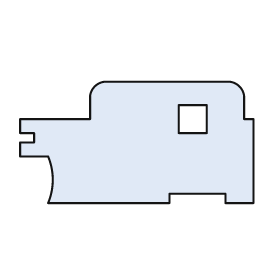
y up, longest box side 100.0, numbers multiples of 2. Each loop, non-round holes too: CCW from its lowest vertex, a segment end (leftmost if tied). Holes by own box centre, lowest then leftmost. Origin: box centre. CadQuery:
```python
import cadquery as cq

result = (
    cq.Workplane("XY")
    .moveTo(-38.0, -26.0)
    .lineTo(14.0, -26.0)
    .lineTo(14.0, -22.0)
    .lineTo(38.0, -22.0)
    .lineTo(38.0, -26.0)
    .lineTo(50.0, -26.0)
    .lineTo(50.0, 10.0)
    .lineTo(46.0, 10.0)
    .lineTo(46.0, 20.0)
    .threePointArc((44.0, 24.0), (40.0, 26.0))
    .lineTo(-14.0, 26.0)
    .threePointArc((-18.0, 24.0), (-20.0, 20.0))
    .lineTo(-20.0, 10.0)
    .lineTo(-50.0, 10.0)
    .lineTo(-50.0, 4.0)
    .lineTo(-44.0, 4.0)
    .lineTo(-44.0, 0.0)
    .lineTo(-50.0, 0.0)
    .lineTo(-50.0, -6.0)
    .lineTo(-38.0, -6.0)
    .threePointArc((-36.0, -16.0), (-38.0, -26.0))
    .close()
    .moveTo(18.0, 4.0)
    .lineTo(30.0, 4.0)
    .lineTo(30.0, 16.0)
    .lineTo(18.0, 16.0)
    .close()
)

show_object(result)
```